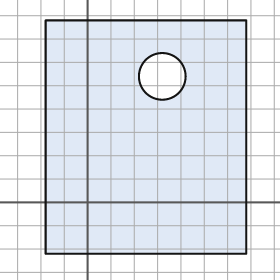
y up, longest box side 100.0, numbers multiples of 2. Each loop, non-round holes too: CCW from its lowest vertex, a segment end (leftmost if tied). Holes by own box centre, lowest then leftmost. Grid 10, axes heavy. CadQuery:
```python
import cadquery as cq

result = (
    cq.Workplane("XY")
    .moveTo(-18.0, -22.0)
    .lineTo(68.0, -22.0)
    .lineTo(68.0, 78.0)
    .lineTo(-18.0, 78.0)
    .close()
    .moveTo(32.0, 54.0)
    .circle(10.0)
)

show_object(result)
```